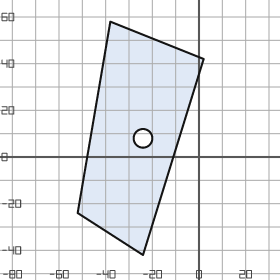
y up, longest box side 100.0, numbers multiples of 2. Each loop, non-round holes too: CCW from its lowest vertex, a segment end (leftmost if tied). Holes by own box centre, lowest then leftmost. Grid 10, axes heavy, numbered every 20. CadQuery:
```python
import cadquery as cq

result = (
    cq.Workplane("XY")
    .moveTo(-24.0, -42.0)
    .lineTo(2.0, 42.0)
    .lineTo(-38.0, 58.0)
    .lineTo(-52.0, -24.0)
    .close()
    .moveTo(-24.0, 8.0)
    .circle(4.0)
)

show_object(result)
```